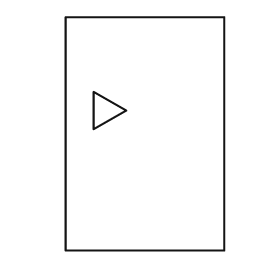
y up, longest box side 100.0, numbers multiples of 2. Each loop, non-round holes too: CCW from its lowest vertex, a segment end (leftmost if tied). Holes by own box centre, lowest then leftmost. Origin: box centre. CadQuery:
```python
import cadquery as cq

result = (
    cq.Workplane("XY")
    .moveTo(-34.0, -50.0)
    .lineTo(34.0, -50.0)
    .lineTo(34.0, 50.0)
    .lineTo(-34.0, 50.0)
    .close()
    .moveTo(-22.0, 2.0)
    .lineTo(-8.0, 10.0)
    .lineTo(-22.0, 18.0)
    .close()
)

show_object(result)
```